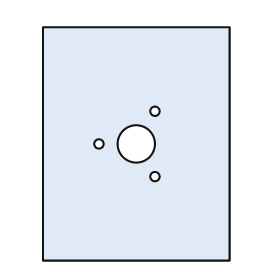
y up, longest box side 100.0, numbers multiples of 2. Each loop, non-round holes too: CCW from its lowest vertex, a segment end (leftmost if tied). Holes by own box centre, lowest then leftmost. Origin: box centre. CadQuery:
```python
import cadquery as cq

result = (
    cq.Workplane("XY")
    .moveTo(-40.0, -50.0)
    .lineTo(40.0, -50.0)
    .lineTo(40.0, 50.0)
    .lineTo(-40.0, 50.0)
    .close()
    .moveTo(8.0, -14.0)
    .circle(2.0)
    .moveTo(-16.0, 0.0)
    .circle(2.0)
    .moveTo(0.0, 0.0)
    .circle(8.0)
    .moveTo(8.0, 14.0)
    .circle(2.0)
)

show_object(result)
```